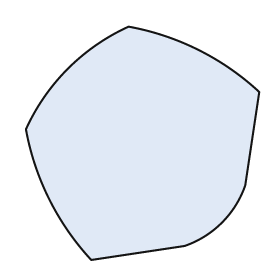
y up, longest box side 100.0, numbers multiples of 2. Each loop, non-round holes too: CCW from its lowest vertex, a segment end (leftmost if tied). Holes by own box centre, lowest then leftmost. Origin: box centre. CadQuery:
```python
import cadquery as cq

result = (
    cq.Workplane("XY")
    .moveTo(-22.0, -50.0)
    .lineTo(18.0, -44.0)
    .threePointArc((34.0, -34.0), (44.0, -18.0))
    .lineTo(50.0, 22.0)
    .threePointArc((24.0, 40.0), (-6.0, 50.0))
    .threePointArc((-32.0, 32.0), (-50.0, 6.0))
    .threePointArc((-40.0, -24.0), (-22.0, -50.0))
    .close()
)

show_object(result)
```